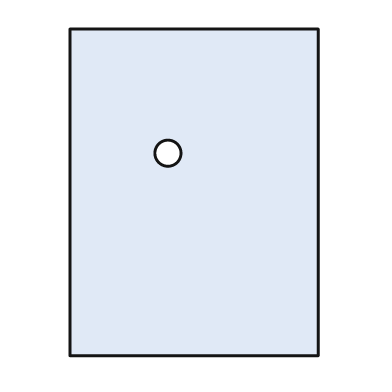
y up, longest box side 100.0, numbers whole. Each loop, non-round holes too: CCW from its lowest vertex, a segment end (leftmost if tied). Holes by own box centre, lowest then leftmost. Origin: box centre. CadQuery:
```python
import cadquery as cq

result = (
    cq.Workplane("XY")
    .moveTo(-38.0, -50.0)
    .lineTo(38.0, -50.0)
    .lineTo(38.0, 50.0)
    .lineTo(-38.0, 50.0)
    .close()
    .moveTo(-8.0, 12.0)
    .circle(4.0)
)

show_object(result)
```